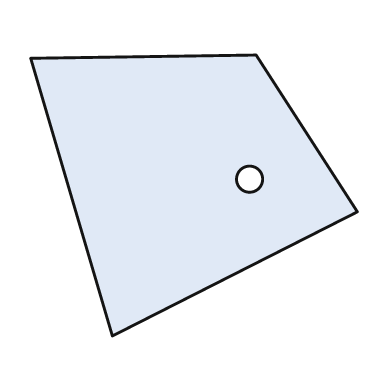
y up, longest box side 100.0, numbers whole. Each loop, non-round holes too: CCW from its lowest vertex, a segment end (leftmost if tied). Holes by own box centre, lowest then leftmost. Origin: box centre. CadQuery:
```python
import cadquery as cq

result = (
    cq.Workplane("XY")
    .moveTo(-25.0, -43.0)
    .lineTo(50.0, -5.0)
    .lineTo(19.0, 43.0)
    .lineTo(-50.0, 42.0)
    .close()
    .moveTo(17.0, 5.0)
    .circle(4.0)
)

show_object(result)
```